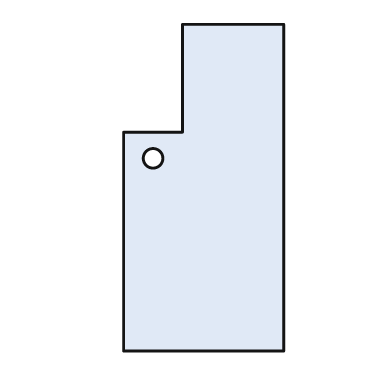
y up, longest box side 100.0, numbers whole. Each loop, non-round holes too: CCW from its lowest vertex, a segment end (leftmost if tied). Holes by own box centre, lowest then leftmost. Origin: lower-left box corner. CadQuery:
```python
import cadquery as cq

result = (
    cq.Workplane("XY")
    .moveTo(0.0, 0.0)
    .lineTo(49.0, 0.0)
    .lineTo(49.0, 100.0)
    .lineTo(18.0, 100.0)
    .lineTo(18.0, 67.0)
    .lineTo(0.0, 67.0)
    .close()
    .moveTo(9.0, 59.0)
    .circle(3.0)
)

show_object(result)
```